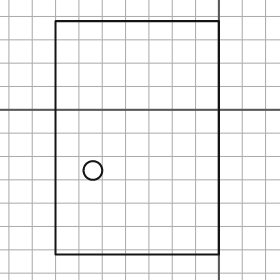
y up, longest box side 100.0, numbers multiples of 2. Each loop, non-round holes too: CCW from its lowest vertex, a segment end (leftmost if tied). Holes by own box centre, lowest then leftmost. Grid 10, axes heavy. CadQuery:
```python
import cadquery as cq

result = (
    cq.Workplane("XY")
    .moveTo(-70.0, -62.0)
    .lineTo(0.0, -62.0)
    .lineTo(0.0, 38.0)
    .lineTo(-70.0, 38.0)
    .close()
    .moveTo(-54.0, -26.0)
    .circle(4.0)
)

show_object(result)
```